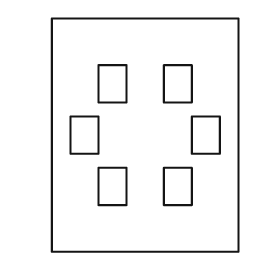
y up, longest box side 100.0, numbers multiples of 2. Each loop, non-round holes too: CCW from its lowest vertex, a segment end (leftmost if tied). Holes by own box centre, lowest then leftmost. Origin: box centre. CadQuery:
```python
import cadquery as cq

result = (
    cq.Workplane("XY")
    .moveTo(-40.0, -50.0)
    .lineTo(40.0, -50.0)
    .lineTo(40.0, 50.0)
    .lineTo(-40.0, 50.0)
    .close()
    .moveTo(-20.0, -30.0)
    .lineTo(-8.0, -30.0)
    .lineTo(-8.0, -14.0)
    .lineTo(-20.0, -14.0)
    .close()
    .moveTo(8.0, -30.0)
    .lineTo(20.0, -30.0)
    .lineTo(20.0, -14.0)
    .lineTo(8.0, -14.0)
    .close()
    .moveTo(-32.0, -8.0)
    .lineTo(-20.0, -8.0)
    .lineTo(-20.0, 8.0)
    .lineTo(-32.0, 8.0)
    .close()
    .moveTo(20.0, -8.0)
    .lineTo(32.0, -8.0)
    .lineTo(32.0, 8.0)
    .lineTo(20.0, 8.0)
    .close()
    .moveTo(-20.0, 14.0)
    .lineTo(-8.0, 14.0)
    .lineTo(-8.0, 30.0)
    .lineTo(-20.0, 30.0)
    .close()
    .moveTo(8.0, 14.0)
    .lineTo(20.0, 14.0)
    .lineTo(20.0, 30.0)
    .lineTo(8.0, 30.0)
    .close()
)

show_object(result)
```